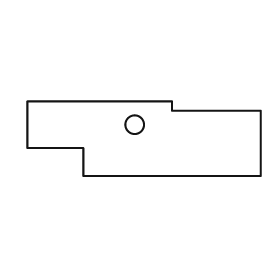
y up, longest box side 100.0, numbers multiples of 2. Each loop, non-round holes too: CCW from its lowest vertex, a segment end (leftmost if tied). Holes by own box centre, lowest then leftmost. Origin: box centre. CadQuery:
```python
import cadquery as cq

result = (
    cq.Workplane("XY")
    .moveTo(-26.0, -16.0)
    .lineTo(50.0, -16.0)
    .lineTo(50.0, 12.0)
    .lineTo(12.0, 12.0)
    .lineTo(12.0, 16.0)
    .lineTo(-50.0, 16.0)
    .lineTo(-50.0, -4.0)
    .lineTo(-26.0, -4.0)
    .close()
    .moveTo(-4.0, 6.0)
    .circle(4.0)
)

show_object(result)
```